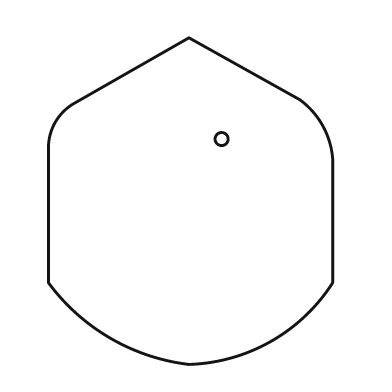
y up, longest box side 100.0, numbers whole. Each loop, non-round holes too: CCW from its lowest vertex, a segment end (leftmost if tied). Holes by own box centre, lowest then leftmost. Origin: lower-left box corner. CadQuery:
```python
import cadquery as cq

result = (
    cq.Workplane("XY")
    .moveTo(43.0, 0.0)
    .threePointArc((68.0, 7.0), (87.0, 25.0))
    .lineTo(87.0, 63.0)
    .threePointArc((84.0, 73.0), (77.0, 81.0))
    .lineTo(43.0, 100.0)
    .lineTo(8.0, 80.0)
    .threePointArc((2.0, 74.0), (0.0, 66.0))
    .lineTo(0.0, 25.0)
    .threePointArc((19.0, 8.0), (43.0, 0.0))
    .close()
    .moveTo(53.0, 69.0)
    .circle(2.0)
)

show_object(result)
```